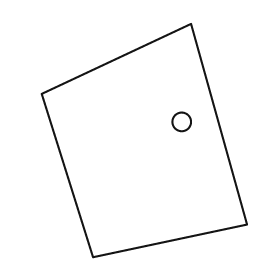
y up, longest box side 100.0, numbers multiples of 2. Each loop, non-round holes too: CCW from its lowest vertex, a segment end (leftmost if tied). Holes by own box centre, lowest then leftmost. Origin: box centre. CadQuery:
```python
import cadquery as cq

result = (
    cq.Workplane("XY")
    .moveTo(-22.0, -50.0)
    .lineTo(44.0, -36.0)
    .lineTo(20.0, 50.0)
    .lineTo(-44.0, 20.0)
    .close()
    .moveTo(16.0, 8.0)
    .circle(4.0)
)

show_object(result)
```